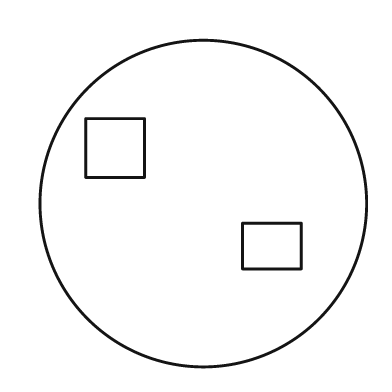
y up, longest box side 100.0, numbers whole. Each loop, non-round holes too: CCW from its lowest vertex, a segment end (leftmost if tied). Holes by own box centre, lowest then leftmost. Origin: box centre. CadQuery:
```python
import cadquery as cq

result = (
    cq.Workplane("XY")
    .moveTo(0.0, 0.0)
    .circle(50.0)
    .moveTo(12.0, -20.0)
    .lineTo(30.0, -20.0)
    .lineTo(30.0, -6.0)
    .lineTo(12.0, -6.0)
    .close()
    .moveTo(-36.0, 8.0)
    .lineTo(-18.0, 8.0)
    .lineTo(-18.0, 26.0)
    .lineTo(-36.0, 26.0)
    .close()
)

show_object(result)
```